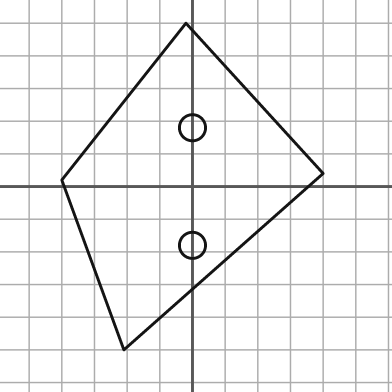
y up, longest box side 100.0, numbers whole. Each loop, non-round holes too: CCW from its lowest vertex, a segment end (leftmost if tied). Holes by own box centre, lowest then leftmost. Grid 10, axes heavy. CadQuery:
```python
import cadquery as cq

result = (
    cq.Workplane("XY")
    .moveTo(-21.0, -50.0)
    .lineTo(40.0, 4.0)
    .lineTo(-2.0, 50.0)
    .lineTo(-40.0, 2.0)
    .close()
    .moveTo(0.0, -18.0)
    .circle(4.0)
    .moveTo(0.0, 18.0)
    .circle(4.0)
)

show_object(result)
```